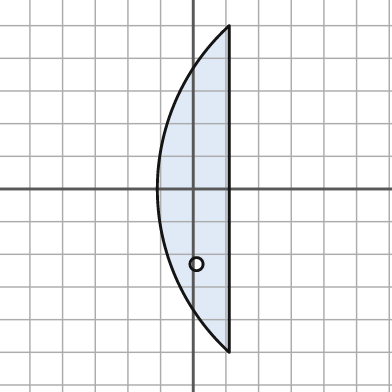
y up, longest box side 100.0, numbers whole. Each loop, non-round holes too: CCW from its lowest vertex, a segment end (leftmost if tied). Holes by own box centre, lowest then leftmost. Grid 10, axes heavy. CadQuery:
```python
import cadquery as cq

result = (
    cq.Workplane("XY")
    .moveTo(11.0, -50.0)
    .lineTo(11.0, 50.0)
    .threePointArc((-11.0, 0.0), (11.0, -50.0))
    .close()
    .moveTo(1.0, -23.0)
    .circle(2.0)
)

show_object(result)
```